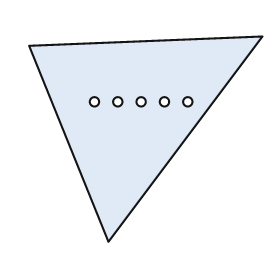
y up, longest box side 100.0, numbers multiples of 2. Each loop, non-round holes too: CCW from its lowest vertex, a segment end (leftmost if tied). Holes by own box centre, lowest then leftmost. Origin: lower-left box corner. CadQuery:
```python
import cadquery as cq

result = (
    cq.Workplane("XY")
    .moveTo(34.0, 0.0)
    .lineTo(100.0, 88.0)
    .lineTo(0.0, 84.0)
    .close()
    .moveTo(28.0, 60.0)
    .circle(2.0)
    .moveTo(38.0, 60.0)
    .circle(2.0)
    .moveTo(48.0, 60.0)
    .circle(2.0)
    .moveTo(58.0, 60.0)
    .circle(2.0)
    .moveTo(68.0, 60.0)
    .circle(2.0)
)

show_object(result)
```